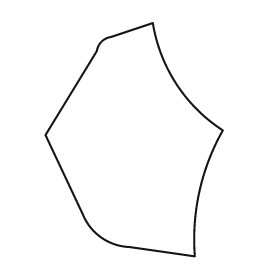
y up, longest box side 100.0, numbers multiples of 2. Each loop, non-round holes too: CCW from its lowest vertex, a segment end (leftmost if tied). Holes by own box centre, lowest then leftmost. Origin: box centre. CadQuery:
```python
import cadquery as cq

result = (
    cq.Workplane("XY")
    .moveTo(26.0, -50.0)
    .threePointArc((28.0, -22.0), (38.0, 4.0))
    .threePointArc((18.0, 24.0), (8.0, 50.0))
    .lineTo(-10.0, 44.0)
    .threePointArc((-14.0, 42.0), (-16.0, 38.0))
    .lineTo(-38.0, 2.0)
    .lineTo(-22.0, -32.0)
    .threePointArc((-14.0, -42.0), (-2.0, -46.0))
    .close()
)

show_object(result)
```